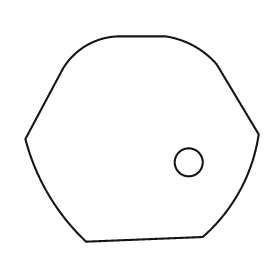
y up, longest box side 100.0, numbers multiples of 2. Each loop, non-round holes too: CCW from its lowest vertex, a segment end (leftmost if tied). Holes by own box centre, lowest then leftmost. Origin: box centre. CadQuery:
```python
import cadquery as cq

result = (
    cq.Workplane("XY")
    .moveTo(-24.0, -44.0)
    .lineTo(26.0, -42.0)
    .threePointArc((42.0, -22.0), (50.0, 2.0))
    .lineTo(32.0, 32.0)
    .threePointArc((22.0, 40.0), (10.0, 44.0))
    .lineTo(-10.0, 44.0)
    .threePointArc((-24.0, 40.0), (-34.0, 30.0))
    .lineTo(-50.0, 0.0)
    .threePointArc((-40.0, -24.0), (-24.0, -44.0))
    .close()
    .moveTo(20.0, -10.0)
    .circle(6.0)
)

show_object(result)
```